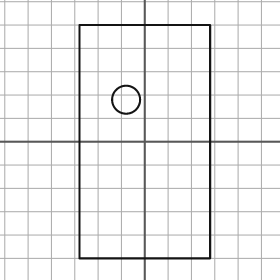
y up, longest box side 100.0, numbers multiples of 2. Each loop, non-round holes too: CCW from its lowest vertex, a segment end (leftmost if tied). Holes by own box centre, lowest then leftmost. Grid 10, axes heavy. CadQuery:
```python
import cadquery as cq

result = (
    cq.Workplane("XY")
    .moveTo(-28.0, -50.0)
    .lineTo(28.0, -50.0)
    .lineTo(28.0, 50.0)
    .lineTo(-28.0, 50.0)
    .close()
    .moveTo(-8.0, 18.0)
    .circle(6.0)
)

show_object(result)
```